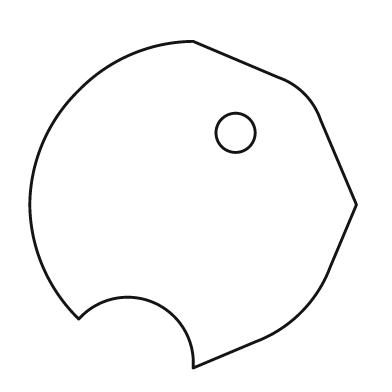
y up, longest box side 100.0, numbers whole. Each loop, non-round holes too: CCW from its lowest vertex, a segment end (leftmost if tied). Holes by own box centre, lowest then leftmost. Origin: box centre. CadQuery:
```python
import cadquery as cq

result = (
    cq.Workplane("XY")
    .moveTo(0.0, -50.0)
    .lineTo(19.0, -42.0)
    .threePointArc((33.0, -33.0), (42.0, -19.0))
    .lineTo(50.0, 0.0)
    .lineTo(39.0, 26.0)
    .threePointArc((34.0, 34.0), (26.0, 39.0))
    .lineTo(0.0, 50.0)
    .threePointArc((-19.0, 46.0), (-35.0, 35.0))
    .threePointArc((-46.0, 19.0), (-50.0, 0.0))
    .threePointArc((-46.0, -19.0), (-35.0, -35.0))
    .threePointArc((-12.0, -30.0), (0.0, -50.0))
    .close()
    .moveTo(13.0, 22.0)
    .circle(6.0)
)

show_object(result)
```